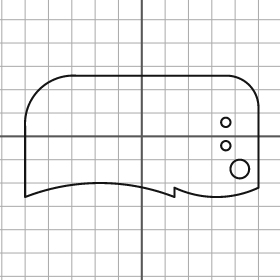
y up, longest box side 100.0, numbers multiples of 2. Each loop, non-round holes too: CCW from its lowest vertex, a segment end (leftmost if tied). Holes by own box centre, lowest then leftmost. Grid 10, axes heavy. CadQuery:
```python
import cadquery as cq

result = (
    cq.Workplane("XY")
    .moveTo(-50.0, -26.0)
    .threePointArc((-18.0, -20.0), (14.0, -26.0))
    .lineTo(14.0, -22.0)
    .threePointArc((32.0, -26.0), (50.0, -22.0))
    .lineTo(50.0, 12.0)
    .threePointArc((46.0, 22.0), (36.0, 26.0))
    .lineTo(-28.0, 26.0)
    .threePointArc((-44.0, 20.0), (-50.0, 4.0))
    .close()
    .moveTo(42.0, -14.0)
    .circle(4.0)
    .moveTo(36.0, -4.0)
    .circle(2.0)
    .moveTo(36.0, 6.0)
    .circle(2.0)
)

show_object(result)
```